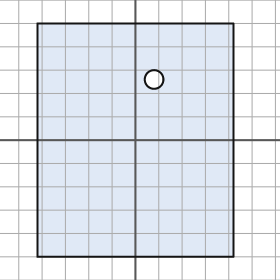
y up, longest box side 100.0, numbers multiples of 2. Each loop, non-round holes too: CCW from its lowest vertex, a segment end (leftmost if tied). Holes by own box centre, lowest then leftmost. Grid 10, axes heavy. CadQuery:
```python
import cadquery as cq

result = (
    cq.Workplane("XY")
    .moveTo(-42.0, -50.0)
    .lineTo(42.0, -50.0)
    .lineTo(42.0, 50.0)
    .lineTo(-42.0, 50.0)
    .close()
    .moveTo(8.0, 26.0)
    .circle(4.0)
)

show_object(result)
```